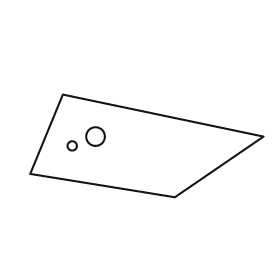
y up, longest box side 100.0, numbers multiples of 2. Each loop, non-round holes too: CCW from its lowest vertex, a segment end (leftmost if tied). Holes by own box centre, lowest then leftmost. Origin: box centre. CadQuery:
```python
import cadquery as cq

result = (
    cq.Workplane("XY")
    .moveTo(12.0, -22.0)
    .lineTo(50.0, 4.0)
    .lineTo(-36.0, 22.0)
    .lineTo(-50.0, -12.0)
    .close()
    .moveTo(-32.0, 0.0)
    .circle(2.0)
    .moveTo(-22.0, 4.0)
    .circle(4.0)
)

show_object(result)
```